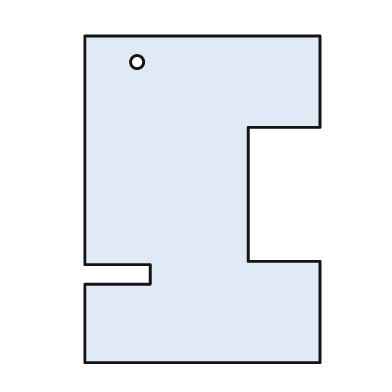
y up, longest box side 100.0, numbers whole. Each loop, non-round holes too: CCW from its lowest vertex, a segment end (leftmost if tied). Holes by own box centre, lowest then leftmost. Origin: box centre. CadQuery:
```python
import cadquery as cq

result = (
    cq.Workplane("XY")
    .moveTo(-36.0, -50.0)
    .lineTo(36.0, -50.0)
    .lineTo(36.0, -19.0)
    .lineTo(14.0, -19.0)
    .lineTo(14.0, 22.0)
    .lineTo(36.0, 22.0)
    .lineTo(36.0, 50.0)
    .lineTo(-36.0, 50.0)
    .lineTo(-36.0, -20.0)
    .lineTo(-16.0, -20.0)
    .lineTo(-16.0, -26.0)
    .lineTo(-36.0, -26.0)
    .close()
    .moveTo(-20.0, 42.0)
    .circle(2.0)
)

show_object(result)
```